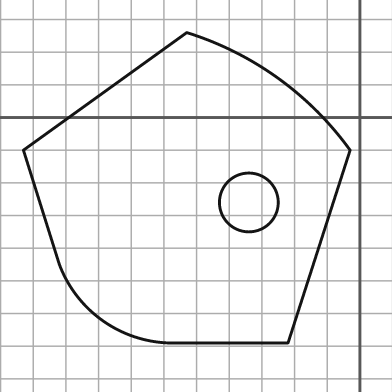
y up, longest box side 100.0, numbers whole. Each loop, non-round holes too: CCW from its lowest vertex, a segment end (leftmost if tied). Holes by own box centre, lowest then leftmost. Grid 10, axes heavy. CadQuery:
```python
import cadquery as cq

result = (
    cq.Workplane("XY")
    .moveTo(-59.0, -69.0)
    .lineTo(-22.0, -69.0)
    .lineTo(-3.0, -10.0)
    .threePointArc((-25.0, 12.0), (-53.0, 26.0))
    .lineTo(-103.0, -10.0)
    .lineTo(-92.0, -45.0)
    .threePointArc((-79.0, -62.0), (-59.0, -69.0))
    .close()
    .moveTo(-34.0, -26.0)
    .circle(9.0)
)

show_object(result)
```